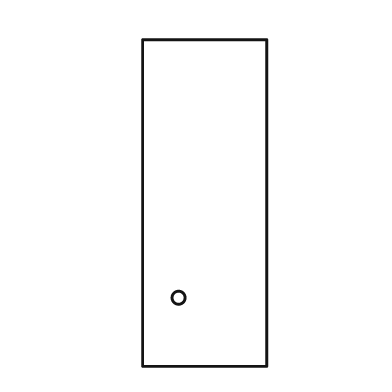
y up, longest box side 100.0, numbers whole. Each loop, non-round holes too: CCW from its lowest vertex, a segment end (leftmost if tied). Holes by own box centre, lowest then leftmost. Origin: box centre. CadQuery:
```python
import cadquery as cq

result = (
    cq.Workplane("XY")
    .moveTo(-19.0, -50.0)
    .lineTo(19.0, -50.0)
    .lineTo(19.0, 50.0)
    .lineTo(-19.0, 50.0)
    .close()
    .moveTo(-8.0, -29.0)
    .circle(2.0)
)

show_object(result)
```